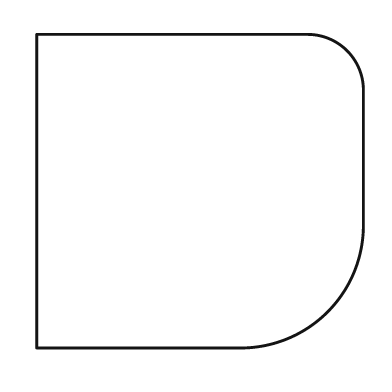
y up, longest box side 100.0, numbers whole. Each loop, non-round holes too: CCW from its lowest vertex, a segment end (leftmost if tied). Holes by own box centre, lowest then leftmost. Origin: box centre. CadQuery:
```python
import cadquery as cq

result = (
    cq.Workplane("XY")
    .moveTo(-50.0, -48.0)
    .lineTo(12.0, -48.0)
    .threePointArc((39.0, -37.0), (50.0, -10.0))
    .lineTo(50.0, 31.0)
    .threePointArc((45.0, 43.0), (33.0, 48.0))
    .lineTo(-50.0, 48.0)
    .close()
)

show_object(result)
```